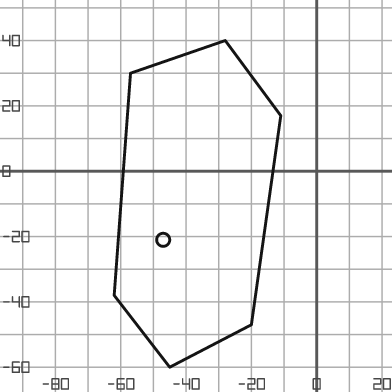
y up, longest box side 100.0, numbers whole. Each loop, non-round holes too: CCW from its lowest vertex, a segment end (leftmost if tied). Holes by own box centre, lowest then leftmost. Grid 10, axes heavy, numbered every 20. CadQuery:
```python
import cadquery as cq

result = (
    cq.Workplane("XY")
    .moveTo(-45.0, -60.0)
    .lineTo(-20.0, -47.0)
    .lineTo(-11.0, 17.0)
    .lineTo(-28.0, 40.0)
    .lineTo(-57.0, 30.0)
    .lineTo(-62.0, -38.0)
    .close()
    .moveTo(-47.0, -21.0)
    .circle(2.0)
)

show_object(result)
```